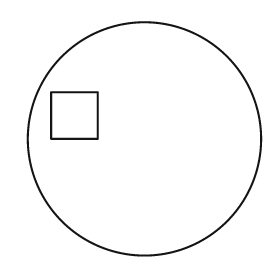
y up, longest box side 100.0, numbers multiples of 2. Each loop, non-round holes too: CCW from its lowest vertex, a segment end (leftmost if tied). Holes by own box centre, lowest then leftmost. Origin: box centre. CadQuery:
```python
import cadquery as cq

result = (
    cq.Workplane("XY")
    .moveTo(0.0, 0.0)
    .circle(50.0)
    .moveTo(-40.0, 0.0)
    .lineTo(-20.0, 0.0)
    .lineTo(-20.0, 20.0)
    .lineTo(-40.0, 20.0)
    .close()
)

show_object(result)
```